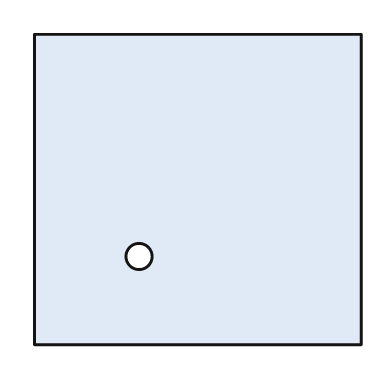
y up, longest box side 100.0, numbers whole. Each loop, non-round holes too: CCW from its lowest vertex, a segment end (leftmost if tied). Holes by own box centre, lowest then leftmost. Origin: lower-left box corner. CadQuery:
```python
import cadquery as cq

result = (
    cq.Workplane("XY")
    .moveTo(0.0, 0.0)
    .lineTo(100.0, 0.0)
    .lineTo(100.0, 95.0)
    .lineTo(0.0, 95.0)
    .close()
    .moveTo(32.0, 27.0)
    .circle(4.0)
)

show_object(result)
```